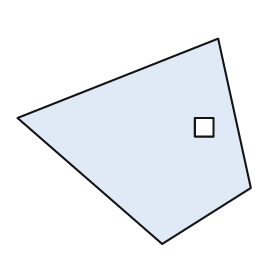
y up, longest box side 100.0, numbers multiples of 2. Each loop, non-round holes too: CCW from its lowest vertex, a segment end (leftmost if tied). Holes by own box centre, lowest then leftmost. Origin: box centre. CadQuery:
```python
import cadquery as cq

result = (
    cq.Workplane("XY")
    .moveTo(12.0, -44.0)
    .lineTo(50.0, -20.0)
    .lineTo(36.0, 44.0)
    .lineTo(-50.0, 10.0)
    .close()
    .moveTo(26.0, 2.0)
    .lineTo(34.0, 2.0)
    .lineTo(34.0, 10.0)
    .lineTo(26.0, 10.0)
    .close()
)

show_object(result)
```